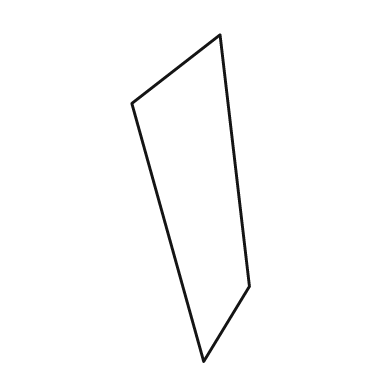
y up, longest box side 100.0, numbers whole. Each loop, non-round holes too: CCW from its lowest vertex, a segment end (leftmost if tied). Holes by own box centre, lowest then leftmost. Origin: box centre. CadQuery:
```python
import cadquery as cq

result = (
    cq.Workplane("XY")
    .moveTo(4.0, -50.0)
    .lineTo(18.0, -27.0)
    .lineTo(9.0, 50.0)
    .lineTo(-18.0, 29.0)
    .close()
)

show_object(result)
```